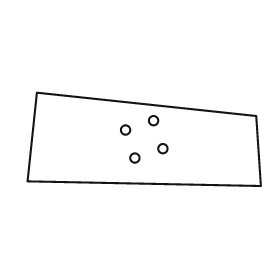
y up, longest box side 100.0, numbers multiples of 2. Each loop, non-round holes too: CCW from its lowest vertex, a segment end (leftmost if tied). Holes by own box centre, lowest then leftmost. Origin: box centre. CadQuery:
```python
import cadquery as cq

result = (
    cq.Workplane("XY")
    .moveTo(50.0, -20.0)
    .lineTo(48.0, 10.0)
    .lineTo(-46.0, 20.0)
    .lineTo(-50.0, -18.0)
    .close()
    .moveTo(-4.0, -8.0)
    .circle(2.0)
    .moveTo(8.0, -4.0)
    .circle(2.0)
    .moveTo(-8.0, 4.0)
    .circle(2.0)
    .moveTo(4.0, 8.0)
    .circle(2.0)
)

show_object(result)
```